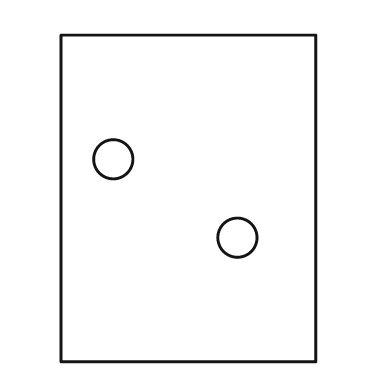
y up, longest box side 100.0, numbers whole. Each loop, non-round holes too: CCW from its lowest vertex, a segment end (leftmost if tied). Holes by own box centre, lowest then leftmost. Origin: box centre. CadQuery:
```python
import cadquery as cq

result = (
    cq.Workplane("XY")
    .moveTo(-39.0, -50.0)
    .lineTo(39.0, -50.0)
    .lineTo(39.0, 50.0)
    .lineTo(-39.0, 50.0)
    .close()
    .moveTo(15.0, -12.0)
    .circle(6.0)
    .moveTo(-23.0, 12.0)
    .circle(6.0)
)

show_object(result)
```